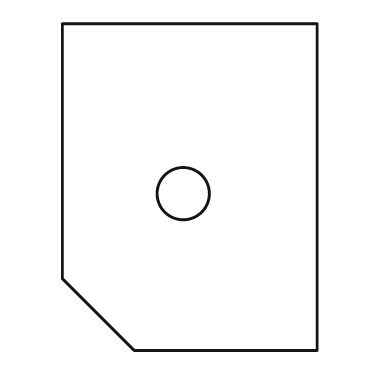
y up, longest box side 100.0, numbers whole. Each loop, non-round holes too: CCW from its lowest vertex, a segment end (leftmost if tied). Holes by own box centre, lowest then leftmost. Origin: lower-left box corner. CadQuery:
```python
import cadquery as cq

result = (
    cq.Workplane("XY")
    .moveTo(22.0, 0.0)
    .lineTo(78.0, 0.0)
    .lineTo(78.0, 100.0)
    .lineTo(0.0, 100.0)
    .lineTo(0.0, 22.0)
    .close()
    .moveTo(37.0, 48.0)
    .circle(8.0)
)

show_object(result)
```